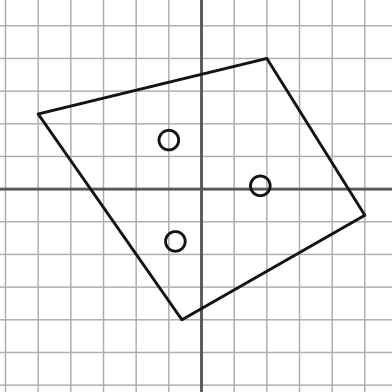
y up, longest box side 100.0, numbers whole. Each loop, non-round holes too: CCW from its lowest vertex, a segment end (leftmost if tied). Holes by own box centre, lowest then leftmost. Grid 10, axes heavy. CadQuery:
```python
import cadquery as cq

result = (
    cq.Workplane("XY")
    .moveTo(-6.0, -40.0)
    .lineTo(50.0, -8.0)
    .lineTo(20.0, 40.0)
    .lineTo(-50.0, 23.0)
    .close()
    .moveTo(-8.0, -16.0)
    .circle(3.0)
    .moveTo(18.0, 1.0)
    .circle(3.0)
    .moveTo(-10.0, 15.0)
    .circle(3.0)
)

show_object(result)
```